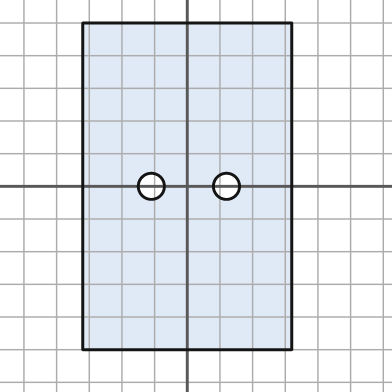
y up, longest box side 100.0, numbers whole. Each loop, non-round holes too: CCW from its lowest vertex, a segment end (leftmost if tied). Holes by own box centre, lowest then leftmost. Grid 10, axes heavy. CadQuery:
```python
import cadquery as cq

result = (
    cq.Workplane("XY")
    .moveTo(-32.0, -50.0)
    .lineTo(32.0, -50.0)
    .lineTo(32.0, 50.0)
    .lineTo(-32.0, 50.0)
    .close()
    .moveTo(-11.0, 0.0)
    .circle(4.0)
    .moveTo(12.0, 0.0)
    .circle(4.0)
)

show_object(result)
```